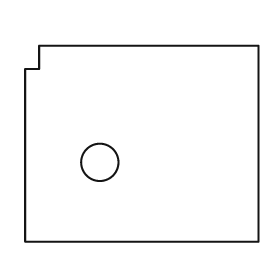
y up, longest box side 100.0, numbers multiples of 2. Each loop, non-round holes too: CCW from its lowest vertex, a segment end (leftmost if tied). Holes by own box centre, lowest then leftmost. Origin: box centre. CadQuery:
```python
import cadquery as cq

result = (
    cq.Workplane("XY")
    .moveTo(-50.0, -42.0)
    .lineTo(50.0, -42.0)
    .lineTo(50.0, 42.0)
    .lineTo(-44.0, 42.0)
    .lineTo(-44.0, 32.0)
    .lineTo(-50.0, 32.0)
    .close()
    .moveTo(-18.0, -8.0)
    .circle(8.0)
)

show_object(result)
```